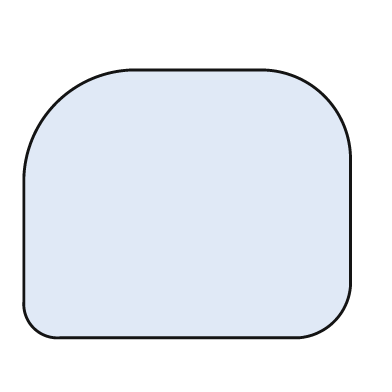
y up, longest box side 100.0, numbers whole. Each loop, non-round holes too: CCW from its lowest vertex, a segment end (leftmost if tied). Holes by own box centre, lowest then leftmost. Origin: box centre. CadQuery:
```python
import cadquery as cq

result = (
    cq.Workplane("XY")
    .moveTo(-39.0, -41.0)
    .lineTo(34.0, -41.0)
    .threePointArc((45.0, -36.0), (50.0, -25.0))
    .lineTo(50.0, 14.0)
    .threePointArc((42.0, 33.0), (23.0, 41.0))
    .lineTo(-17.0, 41.0)
    .threePointArc((-40.0, 31.0), (-50.0, 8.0))
    .lineTo(-50.0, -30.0)
    .threePointArc((-47.0, -38.0), (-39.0, -41.0))
    .close()
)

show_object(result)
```